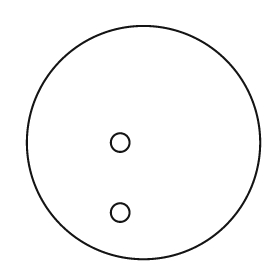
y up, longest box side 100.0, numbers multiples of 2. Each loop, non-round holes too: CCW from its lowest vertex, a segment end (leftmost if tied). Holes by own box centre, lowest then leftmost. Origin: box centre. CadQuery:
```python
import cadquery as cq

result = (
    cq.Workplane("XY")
    .moveTo(0.0, 0.0)
    .circle(50.0)
    .moveTo(-10.0, -30.0)
    .circle(4.0)
    .moveTo(-10.0, 0.0)
    .circle(4.0)
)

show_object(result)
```